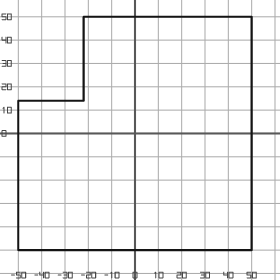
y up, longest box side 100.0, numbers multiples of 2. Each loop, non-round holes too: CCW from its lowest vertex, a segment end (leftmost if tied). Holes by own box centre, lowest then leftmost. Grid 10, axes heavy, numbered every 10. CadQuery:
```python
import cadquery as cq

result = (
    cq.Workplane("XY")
    .moveTo(-50.0, -50.0)
    .lineTo(50.0, -50.0)
    .lineTo(50.0, 50.0)
    .lineTo(-22.0, 50.0)
    .lineTo(-22.0, 14.0)
    .lineTo(-50.0, 14.0)
    .close()
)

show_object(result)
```